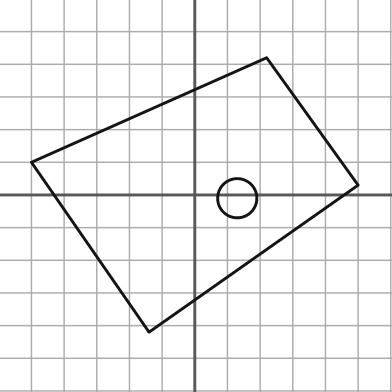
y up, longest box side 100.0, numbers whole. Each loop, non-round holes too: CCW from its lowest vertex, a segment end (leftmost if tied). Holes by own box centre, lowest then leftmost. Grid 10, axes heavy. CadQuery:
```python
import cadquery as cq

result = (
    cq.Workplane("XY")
    .moveTo(-14.0, -42.0)
    .lineTo(50.0, 3.0)
    .lineTo(22.0, 42.0)
    .lineTo(-50.0, 10.0)
    .close()
    .moveTo(13.0, -1.0)
    .circle(6.0)
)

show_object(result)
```